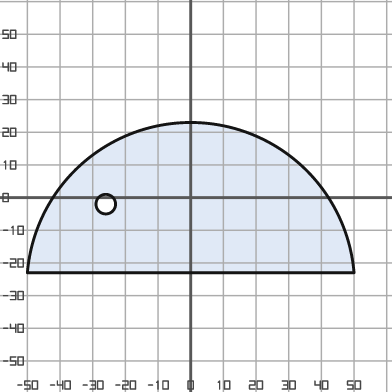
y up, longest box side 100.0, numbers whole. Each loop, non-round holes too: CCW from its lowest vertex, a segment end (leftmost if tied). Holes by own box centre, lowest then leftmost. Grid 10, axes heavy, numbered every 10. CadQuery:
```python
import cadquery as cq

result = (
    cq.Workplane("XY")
    .moveTo(-50.0, -23.0)
    .lineTo(50.0, -23.0)
    .threePointArc((0.0, 23.0), (-50.0, -23.0))
    .close()
    .moveTo(-26.0, -2.0)
    .circle(3.0)
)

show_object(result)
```